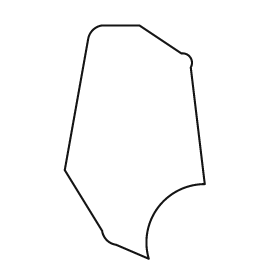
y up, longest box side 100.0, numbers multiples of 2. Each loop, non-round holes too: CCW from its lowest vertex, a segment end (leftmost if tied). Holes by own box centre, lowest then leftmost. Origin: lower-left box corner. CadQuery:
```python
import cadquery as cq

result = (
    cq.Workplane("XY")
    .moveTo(36.0, 0.0)
    .threePointArc((40.0, 22.0), (60.0, 32.0))
    .lineTo(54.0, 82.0)
    .threePointArc((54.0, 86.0), (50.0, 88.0))
    .lineTo(32.0, 100.0)
    .lineTo(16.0, 100.0)
    .threePointArc((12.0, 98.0), (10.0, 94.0))
    .lineTo(0.0, 38.0)
    .lineTo(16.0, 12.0)
    .threePointArc((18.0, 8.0), (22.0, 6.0))
    .close()
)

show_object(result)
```